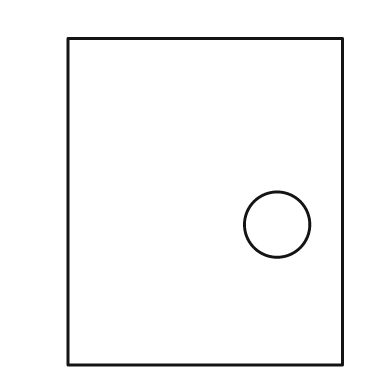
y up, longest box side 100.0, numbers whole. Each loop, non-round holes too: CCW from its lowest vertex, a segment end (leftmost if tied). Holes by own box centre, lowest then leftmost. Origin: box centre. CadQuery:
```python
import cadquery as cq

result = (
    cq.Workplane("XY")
    .moveTo(-42.0, -50.0)
    .lineTo(42.0, -50.0)
    .lineTo(42.0, 50.0)
    .lineTo(-42.0, 50.0)
    .close()
    .moveTo(22.0, -7.0)
    .circle(10.0)
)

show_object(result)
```